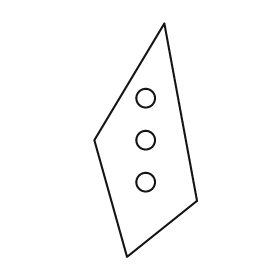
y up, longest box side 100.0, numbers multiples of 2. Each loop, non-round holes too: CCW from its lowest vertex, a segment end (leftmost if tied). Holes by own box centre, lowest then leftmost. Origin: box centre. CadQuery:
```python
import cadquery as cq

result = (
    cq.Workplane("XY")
    .moveTo(-8.0, -50.0)
    .lineTo(22.0, -26.0)
    .lineTo(8.0, 50.0)
    .lineTo(-22.0, 0.0)
    .close()
    .moveTo(0.0, -18.0)
    .circle(4.0)
    .moveTo(0.0, 0.0)
    .circle(4.0)
    .moveTo(0.0, 18.0)
    .circle(4.0)
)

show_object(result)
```